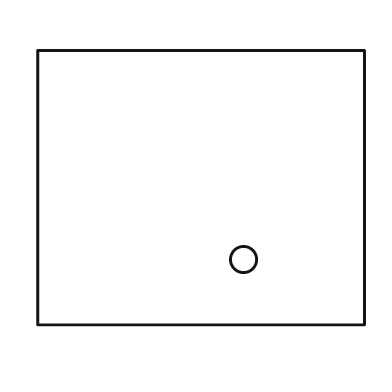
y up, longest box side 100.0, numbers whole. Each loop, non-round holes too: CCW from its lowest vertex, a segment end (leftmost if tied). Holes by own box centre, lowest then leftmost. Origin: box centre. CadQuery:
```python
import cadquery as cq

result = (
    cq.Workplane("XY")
    .moveTo(-50.0, -42.0)
    .lineTo(50.0, -42.0)
    .lineTo(50.0, 42.0)
    .lineTo(-50.0, 42.0)
    .close()
    .moveTo(13.0, -22.0)
    .circle(4.0)
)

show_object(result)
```